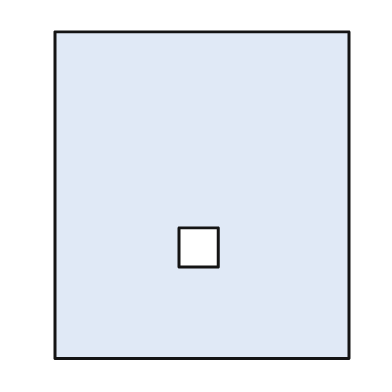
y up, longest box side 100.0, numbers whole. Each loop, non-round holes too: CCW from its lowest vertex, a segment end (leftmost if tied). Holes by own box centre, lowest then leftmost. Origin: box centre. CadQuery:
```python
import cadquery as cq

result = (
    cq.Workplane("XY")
    .moveTo(-45.0, -50.0)
    .lineTo(45.0, -50.0)
    .lineTo(45.0, 50.0)
    .lineTo(-45.0, 50.0)
    .close()
    .moveTo(-7.0, -22.0)
    .lineTo(5.0, -22.0)
    .lineTo(5.0, -10.0)
    .lineTo(-7.0, -10.0)
    .close()
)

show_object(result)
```